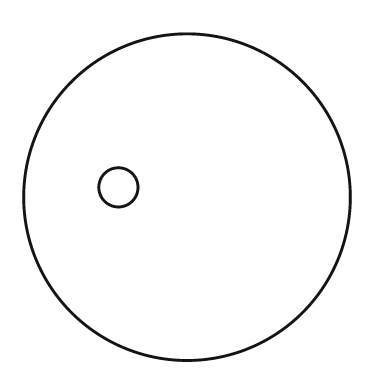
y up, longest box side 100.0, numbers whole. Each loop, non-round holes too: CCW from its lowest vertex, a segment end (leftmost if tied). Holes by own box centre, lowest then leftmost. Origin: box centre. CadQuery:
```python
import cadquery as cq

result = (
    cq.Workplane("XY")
    .moveTo(0.0, 0.0)
    .circle(50.0)
    .moveTo(-21.0, 3.0)
    .circle(6.0)
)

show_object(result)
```